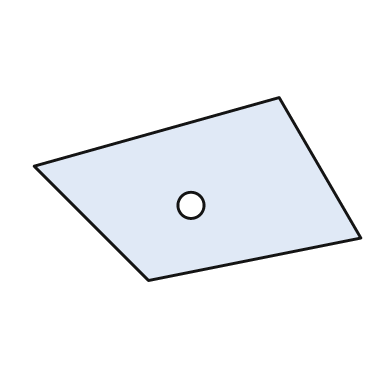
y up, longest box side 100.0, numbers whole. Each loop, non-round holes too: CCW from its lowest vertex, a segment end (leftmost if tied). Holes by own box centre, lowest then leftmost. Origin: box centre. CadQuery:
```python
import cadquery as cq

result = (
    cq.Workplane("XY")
    .moveTo(-15.0, -28.0)
    .lineTo(50.0, -15.0)
    .lineTo(25.0, 28.0)
    .lineTo(-50.0, 7.0)
    .close()
    .moveTo(-2.0, -5.0)
    .circle(4.0)
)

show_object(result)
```